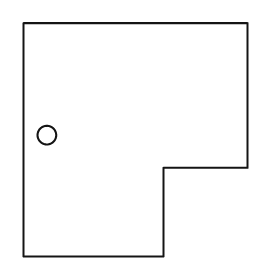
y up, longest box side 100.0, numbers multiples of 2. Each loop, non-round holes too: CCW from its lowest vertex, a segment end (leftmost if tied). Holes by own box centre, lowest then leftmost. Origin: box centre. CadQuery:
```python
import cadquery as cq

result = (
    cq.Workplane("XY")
    .moveTo(-48.0, -50.0)
    .lineTo(12.0, -50.0)
    .lineTo(12.0, -12.0)
    .lineTo(48.0, -12.0)
    .lineTo(48.0, 50.0)
    .lineTo(-48.0, 50.0)
    .close()
    .moveTo(-38.0, 2.0)
    .circle(4.0)
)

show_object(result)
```